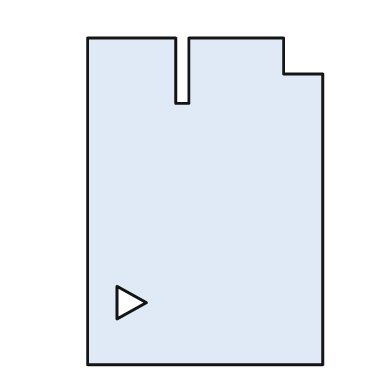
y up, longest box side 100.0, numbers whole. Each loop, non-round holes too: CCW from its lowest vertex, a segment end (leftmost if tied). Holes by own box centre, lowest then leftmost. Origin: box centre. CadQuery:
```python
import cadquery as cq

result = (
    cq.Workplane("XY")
    .moveTo(-36.0, -50.0)
    .lineTo(36.0, -50.0)
    .lineTo(36.0, 39.0)
    .lineTo(24.0, 39.0)
    .lineTo(24.0, 50.0)
    .lineTo(-5.0, 50.0)
    .lineTo(-5.0, 30.0)
    .lineTo(-9.0, 30.0)
    .lineTo(-9.0, 50.0)
    .lineTo(-36.0, 50.0)
    .close()
    .moveTo(-27.0, -36.0)
    .lineTo(-18.0, -31.0)
    .lineTo(-27.0, -26.0)
    .close()
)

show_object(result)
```